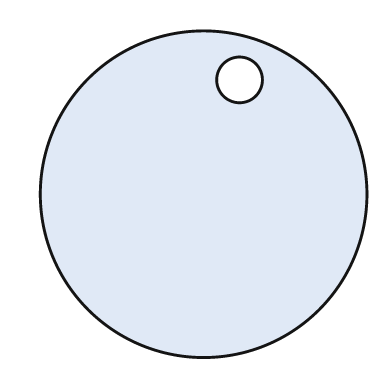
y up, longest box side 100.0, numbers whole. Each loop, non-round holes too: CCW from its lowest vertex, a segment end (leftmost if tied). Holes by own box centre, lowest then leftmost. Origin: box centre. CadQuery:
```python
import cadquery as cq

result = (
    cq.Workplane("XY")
    .moveTo(0.0, 0.0)
    .circle(50.0)
    .moveTo(11.0, 35.0)
    .circle(7.0)
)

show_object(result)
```